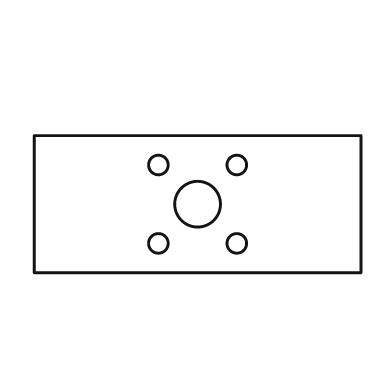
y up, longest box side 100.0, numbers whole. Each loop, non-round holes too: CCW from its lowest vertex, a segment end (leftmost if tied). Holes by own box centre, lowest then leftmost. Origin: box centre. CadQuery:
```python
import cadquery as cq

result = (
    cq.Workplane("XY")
    .moveTo(-50.0, -21.0)
    .lineTo(50.0, -21.0)
    .lineTo(50.0, 21.0)
    .lineTo(-50.0, 21.0)
    .close()
    .moveTo(-12.0, -12.0)
    .circle(3.0)
    .moveTo(12.0, -12.0)
    .circle(3.0)
    .moveTo(0.0, 0.0)
    .circle(7.0)
    .moveTo(-12.0, 12.0)
    .circle(3.0)
    .moveTo(12.0, 12.0)
    .circle(3.0)
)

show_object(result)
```